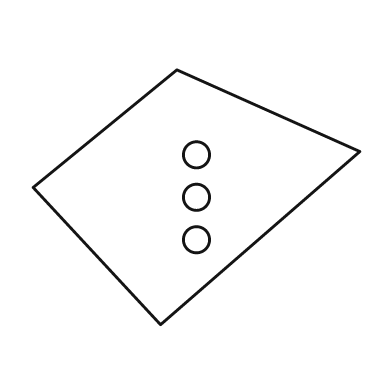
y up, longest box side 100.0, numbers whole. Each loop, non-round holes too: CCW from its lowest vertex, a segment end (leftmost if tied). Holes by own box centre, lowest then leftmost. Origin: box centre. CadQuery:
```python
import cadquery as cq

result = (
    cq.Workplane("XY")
    .moveTo(-11.0, -39.0)
    .lineTo(50.0, 14.0)
    .lineTo(-6.0, 39.0)
    .lineTo(-50.0, 3.0)
    .close()
    .moveTo(0.0, -13.0)
    .circle(4.0)
    .moveTo(0.0, 0.0)
    .circle(4.0)
    .moveTo(0.0, 13.0)
    .circle(4.0)
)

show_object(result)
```